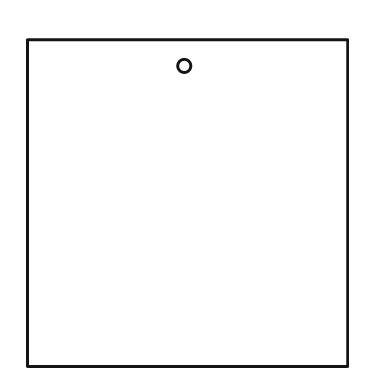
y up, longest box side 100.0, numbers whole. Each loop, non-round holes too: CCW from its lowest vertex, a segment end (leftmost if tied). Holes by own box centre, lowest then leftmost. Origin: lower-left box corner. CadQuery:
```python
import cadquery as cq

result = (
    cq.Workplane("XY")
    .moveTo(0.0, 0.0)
    .lineTo(98.0, 0.0)
    .lineTo(98.0, 100.0)
    .lineTo(0.0, 100.0)
    .close()
    .moveTo(48.0, 92.0)
    .circle(2.0)
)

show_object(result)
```